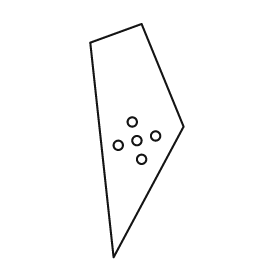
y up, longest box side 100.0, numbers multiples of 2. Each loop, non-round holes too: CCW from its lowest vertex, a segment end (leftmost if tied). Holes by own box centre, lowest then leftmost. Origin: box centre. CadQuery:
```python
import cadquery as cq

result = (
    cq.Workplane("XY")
    .moveTo(-10.0, -50.0)
    .lineTo(20.0, 6.0)
    .lineTo(2.0, 50.0)
    .lineTo(-20.0, 42.0)
    .close()
    .moveTo(2.0, -8.0)
    .circle(2.0)
    .moveTo(-8.0, -2.0)
    .circle(2.0)
    .moveTo(0.0, 0.0)
    .circle(2.0)
    .moveTo(8.0, 2.0)
    .circle(2.0)
    .moveTo(-2.0, 8.0)
    .circle(2.0)
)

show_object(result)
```